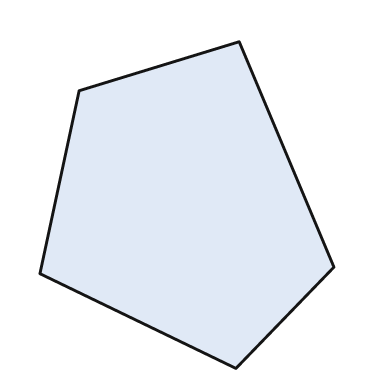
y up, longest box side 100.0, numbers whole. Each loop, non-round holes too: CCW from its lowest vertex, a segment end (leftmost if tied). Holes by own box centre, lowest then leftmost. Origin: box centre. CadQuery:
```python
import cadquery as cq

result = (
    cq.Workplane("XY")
    .moveTo(15.0, -50.0)
    .lineTo(45.0, -19.0)
    .lineTo(16.0, 50.0)
    .lineTo(-33.0, 35.0)
    .lineTo(-45.0, -21.0)
    .close()
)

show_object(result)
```